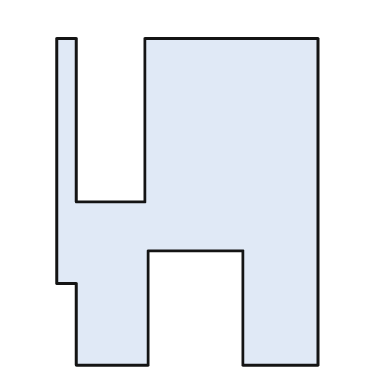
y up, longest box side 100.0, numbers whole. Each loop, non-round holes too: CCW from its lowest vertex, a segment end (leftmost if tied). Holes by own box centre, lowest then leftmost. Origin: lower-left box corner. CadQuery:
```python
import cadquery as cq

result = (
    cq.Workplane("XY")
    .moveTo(6.0, 0.0)
    .lineTo(28.0, 0.0)
    .lineTo(28.0, 35.0)
    .lineTo(57.0, 35.0)
    .lineTo(57.0, 0.0)
    .lineTo(80.0, 0.0)
    .lineTo(80.0, 100.0)
    .lineTo(27.0, 100.0)
    .lineTo(27.0, 50.0)
    .lineTo(6.0, 50.0)
    .lineTo(6.0, 100.0)
    .lineTo(0.0, 100.0)
    .lineTo(0.0, 25.0)
    .lineTo(6.0, 25.0)
    .close()
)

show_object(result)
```